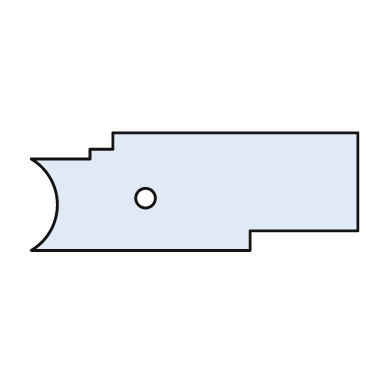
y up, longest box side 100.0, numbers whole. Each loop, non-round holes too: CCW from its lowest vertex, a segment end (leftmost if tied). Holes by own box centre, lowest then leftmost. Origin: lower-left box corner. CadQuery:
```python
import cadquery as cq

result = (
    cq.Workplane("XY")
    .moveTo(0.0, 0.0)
    .lineTo(67.0, 0.0)
    .lineTo(67.0, 6.0)
    .lineTo(100.0, 6.0)
    .lineTo(100.0, 36.0)
    .lineTo(25.0, 36.0)
    .lineTo(25.0, 31.0)
    .lineTo(18.0, 31.0)
    .lineTo(18.0, 28.0)
    .lineTo(0.0, 28.0)
    .threePointArc((8.0, 14.0), (0.0, 0.0))
    .close()
    .moveTo(35.0, 16.0)
    .circle(3.0)
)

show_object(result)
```